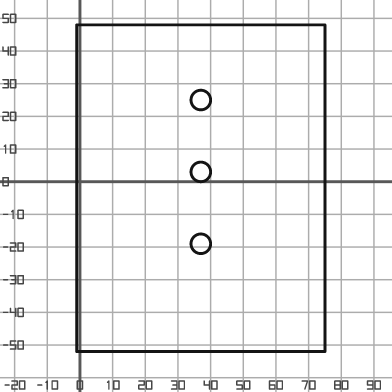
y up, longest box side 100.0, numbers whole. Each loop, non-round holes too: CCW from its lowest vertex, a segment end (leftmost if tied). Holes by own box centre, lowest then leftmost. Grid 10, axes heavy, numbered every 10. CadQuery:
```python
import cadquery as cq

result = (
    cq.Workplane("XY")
    .moveTo(-1.0, -52.0)
    .lineTo(75.0, -52.0)
    .lineTo(75.0, 48.0)
    .lineTo(-1.0, 48.0)
    .close()
    .moveTo(37.0, -19.0)
    .circle(3.0)
    .moveTo(37.0, 3.0)
    .circle(3.0)
    .moveTo(37.0, 25.0)
    .circle(3.0)
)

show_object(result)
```